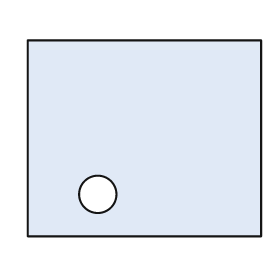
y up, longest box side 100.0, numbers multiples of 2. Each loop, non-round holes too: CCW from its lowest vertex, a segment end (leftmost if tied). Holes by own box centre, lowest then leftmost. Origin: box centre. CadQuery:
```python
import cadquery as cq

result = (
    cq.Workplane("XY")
    .moveTo(-50.0, -42.0)
    .lineTo(50.0, -42.0)
    .lineTo(50.0, 42.0)
    .lineTo(-50.0, 42.0)
    .close()
    .moveTo(-20.0, -24.0)
    .circle(8.0)
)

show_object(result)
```